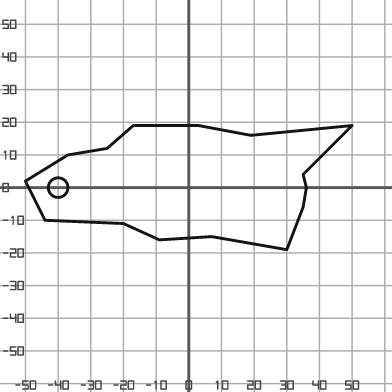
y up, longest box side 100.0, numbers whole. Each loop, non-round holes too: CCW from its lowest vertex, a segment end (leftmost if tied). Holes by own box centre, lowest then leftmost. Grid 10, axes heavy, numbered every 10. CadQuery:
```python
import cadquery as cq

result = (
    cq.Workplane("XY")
    .moveTo(30.0, -19.0)
    .lineTo(35.0, -6.0)
    .lineTo(36.0, 0.0)
    .lineTo(35.0, 4.0)
    .lineTo(50.0, 19.0)
    .lineTo(19.0, 16.0)
    .lineTo(3.0, 19.0)
    .lineTo(-17.0, 19.0)
    .lineTo(-25.0, 12.0)
    .lineTo(-37.0, 10.0)
    .lineTo(-50.0, 2.0)
    .lineTo(-44.0, -10.0)
    .lineTo(-20.0, -11.0)
    .lineTo(-9.0, -16.0)
    .lineTo(7.0, -15.0)
    .close()
    .moveTo(-40.0, 0.0)
    .circle(3.0)
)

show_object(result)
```